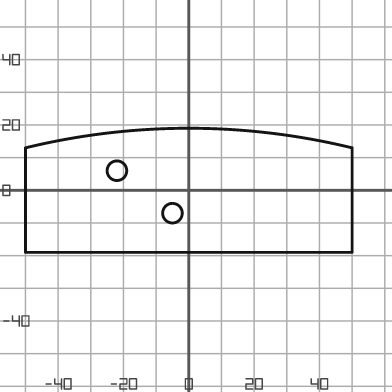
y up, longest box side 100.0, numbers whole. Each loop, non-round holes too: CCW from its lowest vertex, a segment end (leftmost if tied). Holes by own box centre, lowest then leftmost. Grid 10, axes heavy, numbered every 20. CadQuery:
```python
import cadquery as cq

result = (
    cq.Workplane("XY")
    .moveTo(-50.0, -19.0)
    .lineTo(50.0, -19.0)
    .lineTo(50.0, 13.0)
    .threePointArc((0.0, 19.0), (-50.0, 13.0))
    .close()
    .moveTo(-5.0, -7.0)
    .circle(3.0)
    .moveTo(-22.0, 6.0)
    .circle(3.0)
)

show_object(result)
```